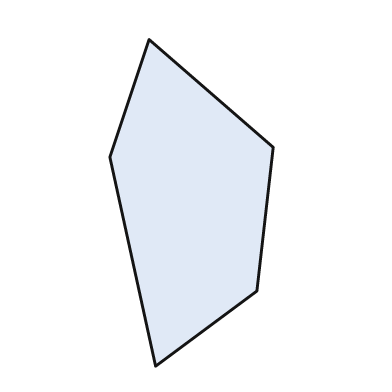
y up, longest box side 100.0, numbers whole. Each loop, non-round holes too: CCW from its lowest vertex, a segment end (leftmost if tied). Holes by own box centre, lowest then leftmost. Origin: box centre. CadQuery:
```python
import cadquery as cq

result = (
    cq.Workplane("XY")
    .moveTo(-11.0, -50.0)
    .lineTo(20.0, -27.0)
    .lineTo(25.0, 17.0)
    .lineTo(-13.0, 50.0)
    .lineTo(-25.0, 14.0)
    .close()
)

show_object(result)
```